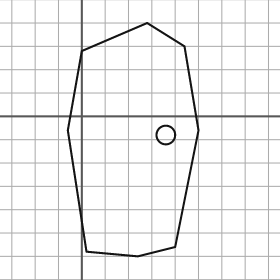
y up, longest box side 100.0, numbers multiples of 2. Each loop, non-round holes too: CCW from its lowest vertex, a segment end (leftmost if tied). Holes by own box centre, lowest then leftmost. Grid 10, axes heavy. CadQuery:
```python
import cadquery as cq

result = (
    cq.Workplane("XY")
    .moveTo(24.0, -60.0)
    .lineTo(40.0, -56.0)
    .lineTo(50.0, -6.0)
    .lineTo(44.0, 30.0)
    .lineTo(28.0, 40.0)
    .lineTo(0.0, 28.0)
    .lineTo(-6.0, -6.0)
    .lineTo(2.0, -58.0)
    .close()
    .moveTo(36.0, -8.0)
    .circle(4.0)
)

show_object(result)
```